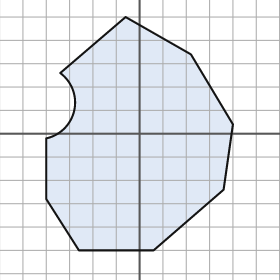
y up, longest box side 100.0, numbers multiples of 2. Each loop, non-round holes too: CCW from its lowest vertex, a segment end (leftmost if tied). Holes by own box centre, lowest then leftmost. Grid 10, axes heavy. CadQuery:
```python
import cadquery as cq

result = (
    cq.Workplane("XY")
    .moveTo(-26.0, -50.0)
    .lineTo(6.0, -50.0)
    .lineTo(36.0, -24.0)
    .lineTo(40.0, 4.0)
    .lineTo(22.0, 34.0)
    .lineTo(-6.0, 50.0)
    .lineTo(-34.0, 26.0)
    .threePointArc((-28.0, 10.0), (-40.0, -2.0))
    .lineTo(-40.0, -28.0)
    .close()
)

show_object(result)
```